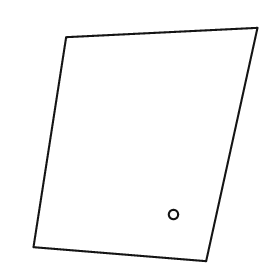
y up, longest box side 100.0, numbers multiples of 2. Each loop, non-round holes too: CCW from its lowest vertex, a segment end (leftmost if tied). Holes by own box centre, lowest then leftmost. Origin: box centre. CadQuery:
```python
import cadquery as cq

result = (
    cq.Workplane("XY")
    .moveTo(26.0, -50.0)
    .lineTo(48.0, 50.0)
    .lineTo(-34.0, 46.0)
    .lineTo(-48.0, -44.0)
    .close()
    .moveTo(12.0, -30.0)
    .circle(2.0)
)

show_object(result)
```